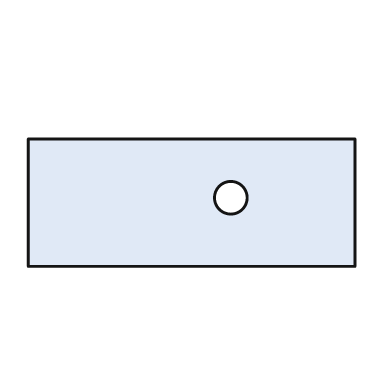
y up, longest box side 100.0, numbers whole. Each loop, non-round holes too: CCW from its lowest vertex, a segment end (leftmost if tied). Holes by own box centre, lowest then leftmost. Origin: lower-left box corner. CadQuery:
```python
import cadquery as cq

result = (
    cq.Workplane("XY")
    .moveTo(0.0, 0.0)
    .lineTo(100.0, 0.0)
    .lineTo(100.0, 39.0)
    .lineTo(0.0, 39.0)
    .close()
    .moveTo(62.0, 21.0)
    .circle(5.0)
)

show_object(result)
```